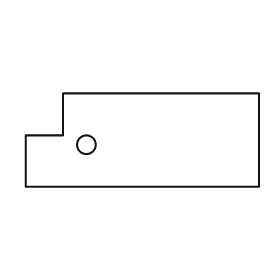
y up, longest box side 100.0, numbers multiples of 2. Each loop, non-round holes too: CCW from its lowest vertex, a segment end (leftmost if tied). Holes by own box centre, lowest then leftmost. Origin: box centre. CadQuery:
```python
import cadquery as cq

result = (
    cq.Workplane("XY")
    .moveTo(-50.0, -20.0)
    .lineTo(50.0, -20.0)
    .lineTo(50.0, 20.0)
    .lineTo(-34.0, 20.0)
    .lineTo(-34.0, 2.0)
    .lineTo(-50.0, 2.0)
    .close()
    .moveTo(-24.0, -2.0)
    .circle(4.0)
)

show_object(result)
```